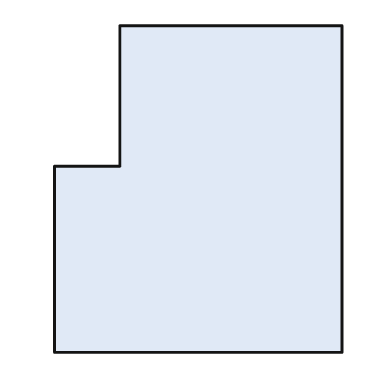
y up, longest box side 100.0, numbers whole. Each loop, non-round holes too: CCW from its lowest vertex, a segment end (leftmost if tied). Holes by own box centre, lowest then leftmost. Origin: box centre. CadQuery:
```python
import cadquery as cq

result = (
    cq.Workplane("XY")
    .moveTo(-44.0, -50.0)
    .lineTo(44.0, -50.0)
    .lineTo(44.0, 50.0)
    .lineTo(-24.0, 50.0)
    .lineTo(-24.0, 7.0)
    .lineTo(-44.0, 7.0)
    .close()
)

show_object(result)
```